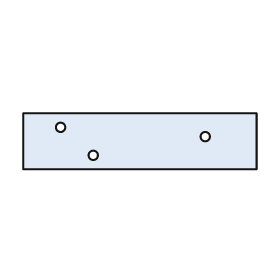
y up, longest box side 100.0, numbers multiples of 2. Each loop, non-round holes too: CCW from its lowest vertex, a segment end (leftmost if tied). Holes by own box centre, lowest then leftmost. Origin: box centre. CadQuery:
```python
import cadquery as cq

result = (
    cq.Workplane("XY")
    .moveTo(-50.0, -12.0)
    .lineTo(50.0, -12.0)
    .lineTo(50.0, 12.0)
    .lineTo(-50.0, 12.0)
    .close()
    .moveTo(-20.0, -6.0)
    .circle(2.0)
    .moveTo(28.0, 2.0)
    .circle(2.0)
    .moveTo(-34.0, 6.0)
    .circle(2.0)
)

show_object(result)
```